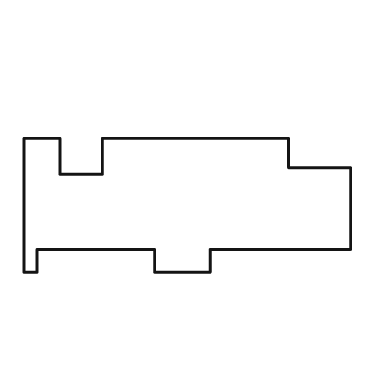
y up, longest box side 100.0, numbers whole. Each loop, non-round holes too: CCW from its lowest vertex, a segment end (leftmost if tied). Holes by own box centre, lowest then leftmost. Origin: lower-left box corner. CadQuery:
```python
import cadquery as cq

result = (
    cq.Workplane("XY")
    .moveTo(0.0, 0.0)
    .lineTo(4.0, 0.0)
    .lineTo(4.0, 7.0)
    .lineTo(40.0, 7.0)
    .lineTo(40.0, 0.0)
    .lineTo(57.0, 0.0)
    .lineTo(57.0, 7.0)
    .lineTo(100.0, 7.0)
    .lineTo(100.0, 32.0)
    .lineTo(81.0, 32.0)
    .lineTo(81.0, 41.0)
    .lineTo(24.0, 41.0)
    .lineTo(24.0, 30.0)
    .lineTo(11.0, 30.0)
    .lineTo(11.0, 41.0)
    .lineTo(0.0, 41.0)
    .close()
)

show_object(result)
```